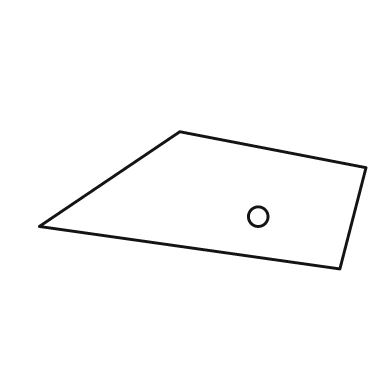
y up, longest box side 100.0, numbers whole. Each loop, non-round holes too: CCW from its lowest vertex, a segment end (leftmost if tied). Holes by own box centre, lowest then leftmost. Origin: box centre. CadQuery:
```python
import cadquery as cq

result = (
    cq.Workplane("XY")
    .moveTo(42.0, -21.0)
    .lineTo(50.0, 10.0)
    .lineTo(-7.0, 21.0)
    .lineTo(-50.0, -8.0)
    .close()
    .moveTo(17.0, -5.0)
    .circle(3.0)
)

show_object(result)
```